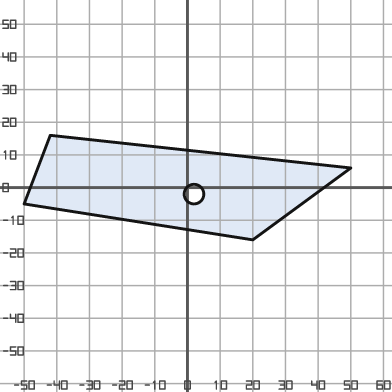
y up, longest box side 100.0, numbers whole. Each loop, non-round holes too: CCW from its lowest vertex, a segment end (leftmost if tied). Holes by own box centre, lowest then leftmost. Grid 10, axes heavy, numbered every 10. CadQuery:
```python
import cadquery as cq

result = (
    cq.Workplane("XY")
    .moveTo(20.0, -16.0)
    .lineTo(50.0, 6.0)
    .lineTo(-42.0, 16.0)
    .lineTo(-50.0, -5.0)
    .close()
    .moveTo(2.0, -2.0)
    .circle(3.0)
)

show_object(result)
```